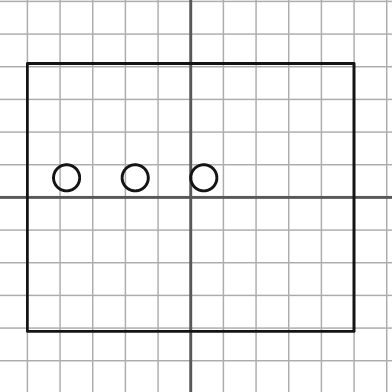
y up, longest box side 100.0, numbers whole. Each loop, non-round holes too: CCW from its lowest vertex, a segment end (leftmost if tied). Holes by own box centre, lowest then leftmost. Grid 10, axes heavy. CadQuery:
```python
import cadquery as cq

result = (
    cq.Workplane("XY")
    .moveTo(-50.0, -41.0)
    .lineTo(50.0, -41.0)
    .lineTo(50.0, 41.0)
    .lineTo(-50.0, 41.0)
    .close()
    .moveTo(-38.0, 6.0)
    .circle(4.0)
    .moveTo(-17.0, 6.0)
    .circle(4.0)
    .moveTo(4.0, 6.0)
    .circle(4.0)
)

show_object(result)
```